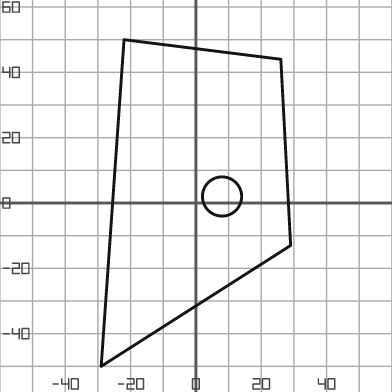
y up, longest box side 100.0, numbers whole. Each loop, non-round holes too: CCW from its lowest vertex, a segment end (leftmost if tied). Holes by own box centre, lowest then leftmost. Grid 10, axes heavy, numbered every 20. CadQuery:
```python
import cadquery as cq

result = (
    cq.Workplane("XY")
    .moveTo(-29.0, -50.0)
    .lineTo(29.0, -13.0)
    .lineTo(26.0, 44.0)
    .lineTo(-22.0, 50.0)
    .close()
    .moveTo(8.0, 2.0)
    .circle(6.0)
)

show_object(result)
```